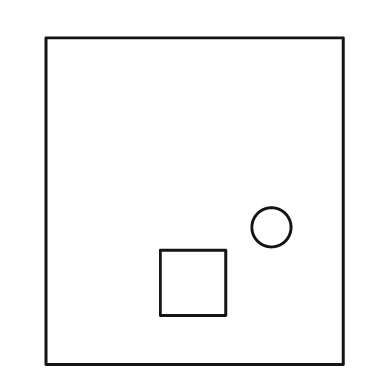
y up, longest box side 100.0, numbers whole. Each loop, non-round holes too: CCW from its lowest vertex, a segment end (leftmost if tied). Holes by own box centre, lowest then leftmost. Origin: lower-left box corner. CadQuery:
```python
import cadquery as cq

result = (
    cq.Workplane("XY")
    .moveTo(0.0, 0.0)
    .lineTo(91.0, 0.0)
    .lineTo(91.0, 100.0)
    .lineTo(0.0, 100.0)
    .close()
    .moveTo(35.0, 15.0)
    .lineTo(55.0, 15.0)
    .lineTo(55.0, 35.0)
    .lineTo(35.0, 35.0)
    .close()
    .moveTo(69.0, 42.0)
    .circle(6.0)
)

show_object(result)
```